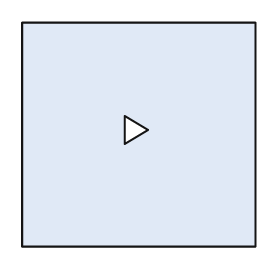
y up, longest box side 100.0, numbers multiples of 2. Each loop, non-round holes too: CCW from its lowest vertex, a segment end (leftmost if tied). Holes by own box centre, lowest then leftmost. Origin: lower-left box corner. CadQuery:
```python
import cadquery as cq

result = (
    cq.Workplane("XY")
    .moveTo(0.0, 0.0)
    .lineTo(100.0, 0.0)
    .lineTo(100.0, 96.0)
    .lineTo(0.0, 96.0)
    .close()
    .moveTo(44.0, 44.0)
    .lineTo(54.0, 50.0)
    .lineTo(44.0, 56.0)
    .close()
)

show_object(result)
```